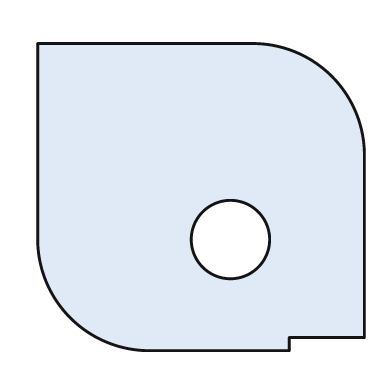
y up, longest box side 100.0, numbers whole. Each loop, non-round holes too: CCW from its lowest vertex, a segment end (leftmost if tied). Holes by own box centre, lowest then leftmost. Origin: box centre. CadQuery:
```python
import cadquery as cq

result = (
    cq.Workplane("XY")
    .moveTo(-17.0, -47.0)
    .lineTo(27.0, -47.0)
    .lineTo(27.0, -43.0)
    .lineTo(50.0, -43.0)
    .lineTo(50.0, 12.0)
    .threePointArc((40.0, 37.0), (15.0, 47.0))
    .lineTo(-50.0, 47.0)
    .lineTo(-50.0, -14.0)
    .threePointArc((-40.0, -37.0), (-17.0, -47.0))
    .close()
    .moveTo(9.0, -13.0)
    .circle(12.0)
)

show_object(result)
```